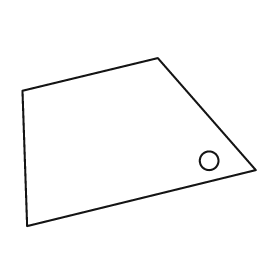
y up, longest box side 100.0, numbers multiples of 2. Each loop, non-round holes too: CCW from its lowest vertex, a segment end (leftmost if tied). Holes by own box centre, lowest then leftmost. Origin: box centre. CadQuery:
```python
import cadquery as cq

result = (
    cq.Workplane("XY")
    .moveTo(-48.0, -36.0)
    .lineTo(50.0, -12.0)
    .lineTo(8.0, 36.0)
    .lineTo(-50.0, 22.0)
    .close()
    .moveTo(30.0, -8.0)
    .circle(4.0)
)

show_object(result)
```